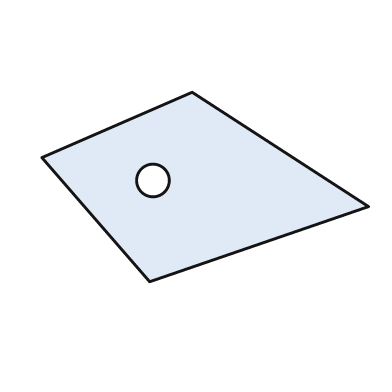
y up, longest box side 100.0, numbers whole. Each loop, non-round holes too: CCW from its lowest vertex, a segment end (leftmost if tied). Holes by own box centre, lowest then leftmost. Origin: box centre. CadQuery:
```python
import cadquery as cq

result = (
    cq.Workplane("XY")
    .moveTo(-17.0, -29.0)
    .lineTo(50.0, -6.0)
    .lineTo(-4.0, 29.0)
    .lineTo(-50.0, 9.0)
    .close()
    .moveTo(-16.0, 2.0)
    .circle(5.0)
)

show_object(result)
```